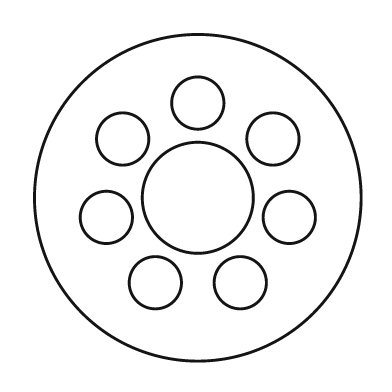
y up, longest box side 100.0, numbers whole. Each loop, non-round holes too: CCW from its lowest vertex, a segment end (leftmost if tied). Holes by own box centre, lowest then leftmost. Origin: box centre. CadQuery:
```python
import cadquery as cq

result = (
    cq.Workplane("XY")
    .moveTo(0.0, 0.0)
    .circle(50.0)
    .moveTo(-13.0, -26.0)
    .circle(8.0)
    .moveTo(13.0, -26.0)
    .circle(8.0)
    .moveTo(-28.0, -6.0)
    .circle(8.0)
    .moveTo(28.0, -6.0)
    .circle(8.0)
    .moveTo(0.0, 0.0)
    .circle(17.0)
    .moveTo(-23.0, 18.0)
    .circle(8.0)
    .moveTo(23.0, 18.0)
    .circle(8.0)
    .moveTo(0.0, 29.0)
    .circle(8.0)
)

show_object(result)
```